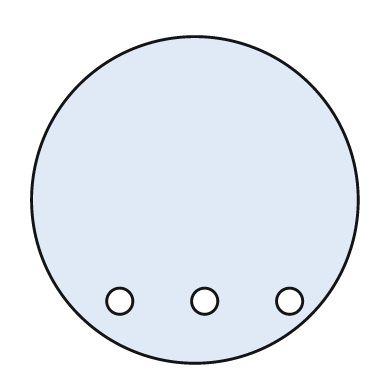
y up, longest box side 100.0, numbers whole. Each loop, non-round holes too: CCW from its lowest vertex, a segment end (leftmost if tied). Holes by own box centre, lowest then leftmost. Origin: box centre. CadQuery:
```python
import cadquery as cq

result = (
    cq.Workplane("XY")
    .moveTo(0.0, 0.0)
    .circle(50.0)
    .moveTo(-23.0, -31.0)
    .circle(4.0)
    .moveTo(3.0, -31.0)
    .circle(4.0)
    .moveTo(29.0, -31.0)
    .circle(4.0)
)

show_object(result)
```